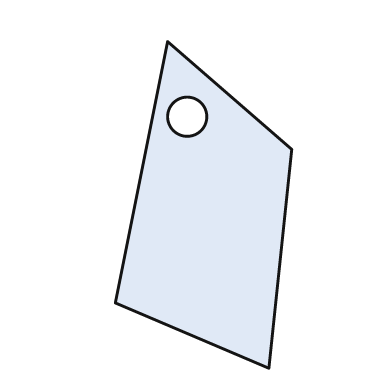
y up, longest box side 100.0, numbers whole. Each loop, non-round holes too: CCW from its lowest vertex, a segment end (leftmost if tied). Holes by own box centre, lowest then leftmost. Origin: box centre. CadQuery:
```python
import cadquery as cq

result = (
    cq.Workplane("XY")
    .moveTo(20.0, -50.0)
    .lineTo(27.0, 17.0)
    .lineTo(-11.0, 50.0)
    .lineTo(-27.0, -30.0)
    .close()
    .moveTo(-5.0, 27.0)
    .circle(6.0)
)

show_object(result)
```